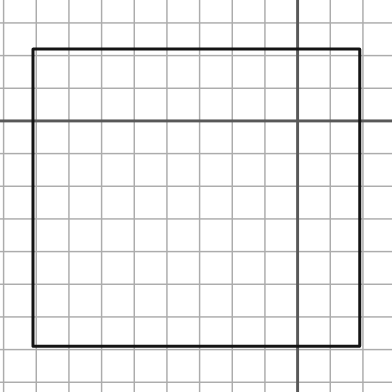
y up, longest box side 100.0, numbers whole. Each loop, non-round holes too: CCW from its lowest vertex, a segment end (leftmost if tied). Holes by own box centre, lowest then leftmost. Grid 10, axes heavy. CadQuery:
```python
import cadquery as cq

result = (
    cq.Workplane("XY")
    .moveTo(-81.0, -69.0)
    .lineTo(19.0, -69.0)
    .lineTo(19.0, 22.0)
    .lineTo(-81.0, 22.0)
    .close()
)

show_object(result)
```